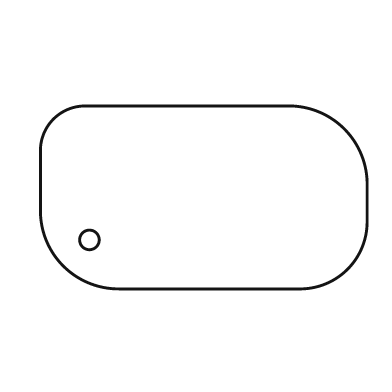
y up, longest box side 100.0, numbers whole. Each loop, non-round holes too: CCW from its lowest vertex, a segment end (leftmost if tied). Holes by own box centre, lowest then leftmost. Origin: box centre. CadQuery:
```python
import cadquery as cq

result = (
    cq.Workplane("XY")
    .moveTo(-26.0, -28.0)
    .lineTo(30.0, -28.0)
    .threePointArc((44.0, -22.0), (50.0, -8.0))
    .lineTo(50.0, 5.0)
    .threePointArc((43.0, 21.0), (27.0, 28.0))
    .lineTo(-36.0, 28.0)
    .threePointArc((-46.0, 24.0), (-50.0, 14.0))
    .lineTo(-50.0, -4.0)
    .threePointArc((-43.0, -21.0), (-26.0, -28.0))
    .close()
    .moveTo(-35.0, -13.0)
    .circle(3.0)
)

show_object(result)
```